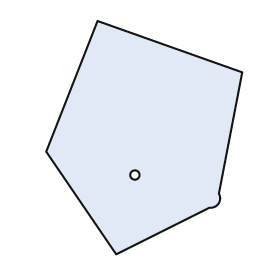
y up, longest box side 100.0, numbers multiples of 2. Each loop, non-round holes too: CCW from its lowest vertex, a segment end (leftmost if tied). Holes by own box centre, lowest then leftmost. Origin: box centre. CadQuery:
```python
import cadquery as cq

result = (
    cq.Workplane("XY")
    .moveTo(-12.0, -50.0)
    .lineTo(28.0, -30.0)
    .threePointArc((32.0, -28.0), (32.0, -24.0))
    .lineTo(42.0, 28.0)
    .lineTo(-20.0, 50.0)
    .lineTo(-42.0, -6.0)
    .close()
    .moveTo(-4.0, -16.0)
    .circle(2.0)
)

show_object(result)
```